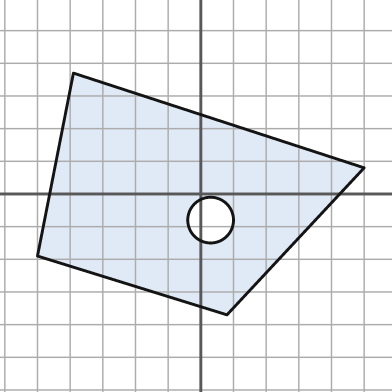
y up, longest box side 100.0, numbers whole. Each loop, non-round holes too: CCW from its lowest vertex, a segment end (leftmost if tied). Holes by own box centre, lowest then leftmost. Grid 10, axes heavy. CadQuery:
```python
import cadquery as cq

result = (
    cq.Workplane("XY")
    .moveTo(8.0, -37.0)
    .lineTo(50.0, 8.0)
    .lineTo(-39.0, 37.0)
    .lineTo(-50.0, -19.0)
    .close()
    .moveTo(3.0, -8.0)
    .circle(7.0)
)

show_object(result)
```